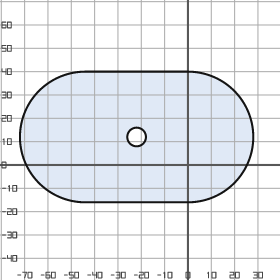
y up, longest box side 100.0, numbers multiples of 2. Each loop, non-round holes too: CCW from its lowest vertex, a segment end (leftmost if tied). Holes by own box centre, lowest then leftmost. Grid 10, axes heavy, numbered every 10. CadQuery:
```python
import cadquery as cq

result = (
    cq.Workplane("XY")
    .moveTo(-44.0, -16.0)
    .lineTo(0.0, -16.0)
    .threePointArc((28.0, 12.0), (0.0, 40.0))
    .lineTo(-44.0, 40.0)
    .threePointArc((-72.0, 12.0), (-44.0, -16.0))
    .close()
    .moveTo(-22.0, 12.0)
    .circle(4.0)
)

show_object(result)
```